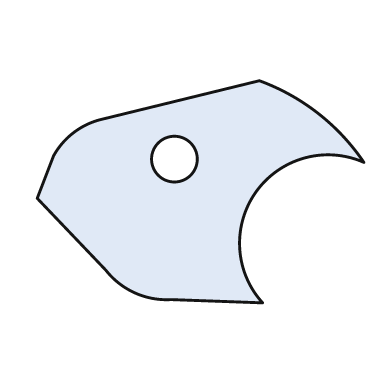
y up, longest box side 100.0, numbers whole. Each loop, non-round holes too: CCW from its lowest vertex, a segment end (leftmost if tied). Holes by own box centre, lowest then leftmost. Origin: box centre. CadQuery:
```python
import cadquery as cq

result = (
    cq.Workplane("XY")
    .moveTo(19.0, -34.0)
    .threePointArc((17.0, 0.0), (50.0, 9.0))
    .threePointArc((36.0, 24.0), (18.0, 34.0))
    .lineTo(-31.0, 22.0)
    .threePointArc((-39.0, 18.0), (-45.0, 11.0))
    .lineTo(-50.0, -2.0)
    .lineTo(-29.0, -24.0)
    .threePointArc((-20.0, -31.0), (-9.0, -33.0))
    .close()
    .moveTo(-8.0, 10.0)
    .circle(7.0)
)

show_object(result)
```